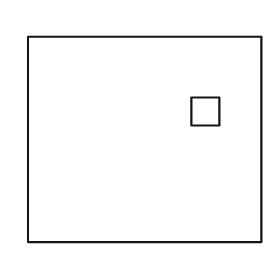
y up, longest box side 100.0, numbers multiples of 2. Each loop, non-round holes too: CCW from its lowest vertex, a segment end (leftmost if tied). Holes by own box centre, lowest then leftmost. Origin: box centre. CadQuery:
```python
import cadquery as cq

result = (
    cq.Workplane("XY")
    .moveTo(-50.0, -44.0)
    .lineTo(50.0, -44.0)
    .lineTo(50.0, 44.0)
    .lineTo(-50.0, 44.0)
    .close()
    .moveTo(20.0, 6.0)
    .lineTo(32.0, 6.0)
    .lineTo(32.0, 18.0)
    .lineTo(20.0, 18.0)
    .close()
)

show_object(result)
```